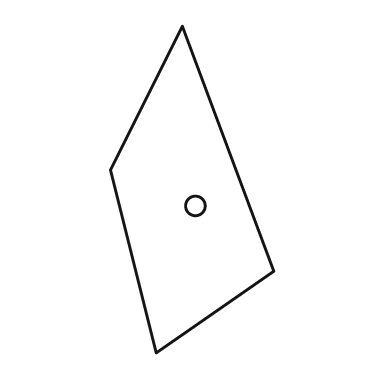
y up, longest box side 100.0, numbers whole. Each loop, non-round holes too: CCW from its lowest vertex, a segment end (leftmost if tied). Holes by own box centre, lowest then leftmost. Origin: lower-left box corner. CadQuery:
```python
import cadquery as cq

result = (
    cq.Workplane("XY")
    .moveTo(14.0, 0.0)
    .lineTo(50.0, 25.0)
    .lineTo(22.0, 100.0)
    .lineTo(0.0, 56.0)
    .close()
    .moveTo(26.0, 45.0)
    .circle(3.0)
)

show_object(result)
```